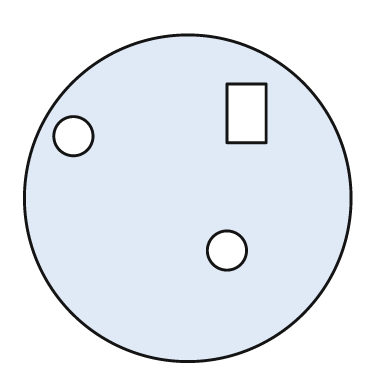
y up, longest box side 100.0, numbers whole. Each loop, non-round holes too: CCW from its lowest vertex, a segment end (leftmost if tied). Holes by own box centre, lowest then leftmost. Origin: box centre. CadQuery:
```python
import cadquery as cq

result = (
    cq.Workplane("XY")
    .moveTo(0.0, 0.0)
    .circle(50.0)
    .moveTo(12.0, -16.0)
    .circle(6.0)
    .moveTo(-35.0, 19.0)
    .circle(6.0)
    .moveTo(12.0, 17.0)
    .lineTo(24.0, 17.0)
    .lineTo(24.0, 35.0)
    .lineTo(12.0, 35.0)
    .close()
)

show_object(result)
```